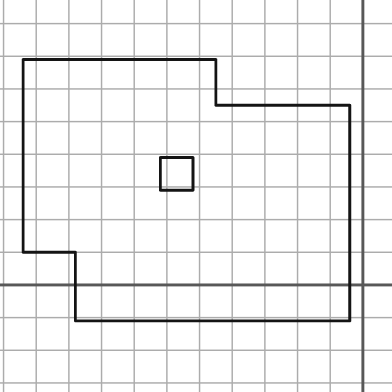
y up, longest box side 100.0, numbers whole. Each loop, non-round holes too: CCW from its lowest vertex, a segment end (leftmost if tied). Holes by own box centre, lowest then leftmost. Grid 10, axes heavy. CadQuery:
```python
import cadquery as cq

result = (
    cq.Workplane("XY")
    .moveTo(-88.0, -11.0)
    .lineTo(-4.0, -11.0)
    .lineTo(-4.0, 55.0)
    .lineTo(-45.0, 55.0)
    .lineTo(-45.0, 69.0)
    .lineTo(-104.0, 69.0)
    .lineTo(-104.0, 10.0)
    .lineTo(-88.0, 10.0)
    .close()
    .moveTo(-62.0, 29.0)
    .lineTo(-52.0, 29.0)
    .lineTo(-52.0, 39.0)
    .lineTo(-62.0, 39.0)
    .close()
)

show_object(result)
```